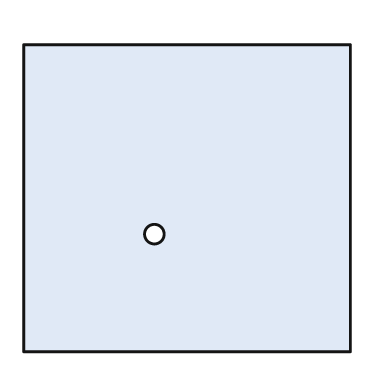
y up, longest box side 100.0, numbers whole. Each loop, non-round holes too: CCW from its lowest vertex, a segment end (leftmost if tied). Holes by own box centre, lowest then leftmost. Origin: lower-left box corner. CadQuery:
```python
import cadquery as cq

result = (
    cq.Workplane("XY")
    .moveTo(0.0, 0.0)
    .lineTo(100.0, 0.0)
    .lineTo(100.0, 94.0)
    .lineTo(0.0, 94.0)
    .close()
    .moveTo(40.0, 36.0)
    .circle(3.0)
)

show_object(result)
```